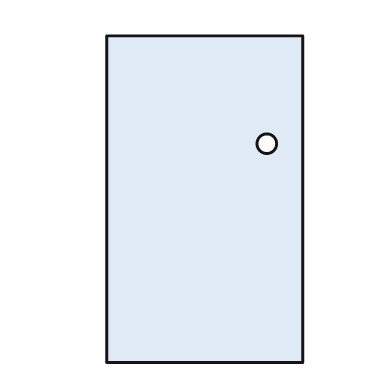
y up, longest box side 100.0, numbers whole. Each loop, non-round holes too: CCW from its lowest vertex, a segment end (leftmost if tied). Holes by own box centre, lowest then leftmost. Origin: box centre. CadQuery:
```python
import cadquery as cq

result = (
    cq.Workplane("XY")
    .moveTo(-30.0, -50.0)
    .lineTo(30.0, -50.0)
    .lineTo(30.0, 50.0)
    .lineTo(-30.0, 50.0)
    .close()
    .moveTo(19.0, 17.0)
    .circle(3.0)
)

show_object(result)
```